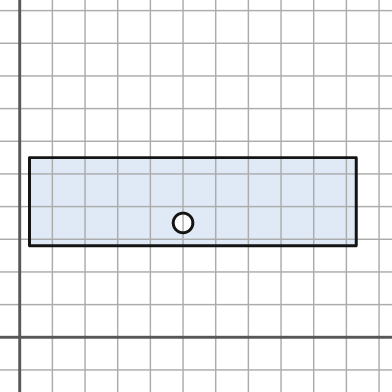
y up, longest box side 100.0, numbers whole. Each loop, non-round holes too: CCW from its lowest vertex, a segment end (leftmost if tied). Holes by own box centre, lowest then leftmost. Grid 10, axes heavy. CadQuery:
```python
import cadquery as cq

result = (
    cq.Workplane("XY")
    .moveTo(3.0, 28.0)
    .lineTo(103.0, 28.0)
    .lineTo(103.0, 55.0)
    .lineTo(3.0, 55.0)
    .close()
    .moveTo(50.0, 35.0)
    .circle(3.0)
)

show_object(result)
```